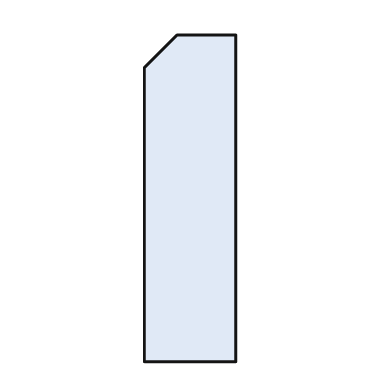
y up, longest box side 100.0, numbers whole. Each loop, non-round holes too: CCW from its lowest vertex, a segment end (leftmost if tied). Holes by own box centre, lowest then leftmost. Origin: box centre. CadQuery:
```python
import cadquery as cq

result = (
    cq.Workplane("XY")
    .moveTo(-14.0, -50.0)
    .lineTo(14.0, -50.0)
    .lineTo(14.0, 50.0)
    .lineTo(-4.0, 50.0)
    .lineTo(-14.0, 40.0)
    .close()
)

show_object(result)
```